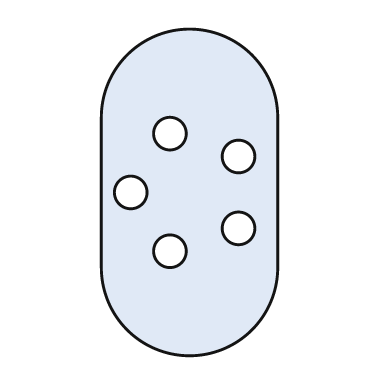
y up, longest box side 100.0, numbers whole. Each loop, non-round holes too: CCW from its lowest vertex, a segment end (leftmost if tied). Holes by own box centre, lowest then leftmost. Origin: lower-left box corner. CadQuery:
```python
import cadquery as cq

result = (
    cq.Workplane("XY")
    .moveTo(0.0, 27.0)
    .threePointArc((27.0, 0.0), (54.0, 27.0))
    .lineTo(54.0, 73.0)
    .threePointArc((27.0, 100.0), (0.0, 73.0))
    .close()
    .moveTo(21.0, 32.0)
    .circle(5.0)
    .moveTo(42.0, 39.0)
    .circle(5.0)
    .moveTo(9.0, 50.0)
    .circle(5.0)
    .moveTo(42.0, 61.0)
    .circle(5.0)
    .moveTo(21.0, 68.0)
    .circle(5.0)
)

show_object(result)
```